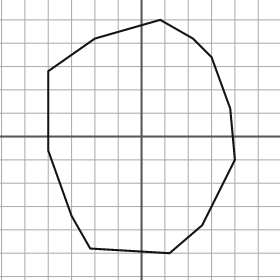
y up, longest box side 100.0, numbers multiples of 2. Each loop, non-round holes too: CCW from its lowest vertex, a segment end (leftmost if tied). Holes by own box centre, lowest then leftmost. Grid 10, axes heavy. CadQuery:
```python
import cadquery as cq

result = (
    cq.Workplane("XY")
    .moveTo(12.0, -50.0)
    .lineTo(26.0, -38.0)
    .lineTo(40.0, -10.0)
    .lineTo(38.0, 12.0)
    .lineTo(30.0, 34.0)
    .lineTo(22.0, 42.0)
    .lineTo(8.0, 50.0)
    .lineTo(-20.0, 42.0)
    .lineTo(-40.0, 28.0)
    .lineTo(-40.0, -6.0)
    .lineTo(-30.0, -34.0)
    .lineTo(-22.0, -48.0)
    .close()
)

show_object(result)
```